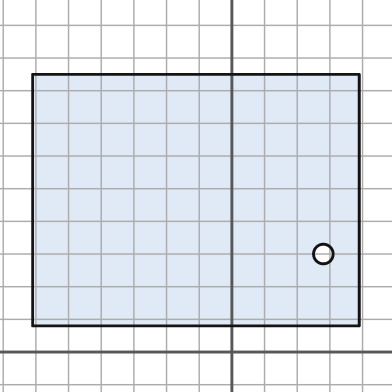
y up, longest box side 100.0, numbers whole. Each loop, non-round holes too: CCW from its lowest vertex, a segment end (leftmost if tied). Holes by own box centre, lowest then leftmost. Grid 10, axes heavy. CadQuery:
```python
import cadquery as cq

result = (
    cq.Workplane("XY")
    .moveTo(-61.0, 8.0)
    .lineTo(39.0, 8.0)
    .lineTo(39.0, 85.0)
    .lineTo(-61.0, 85.0)
    .close()
    .moveTo(28.0, 30.0)
    .circle(3.0)
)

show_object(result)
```